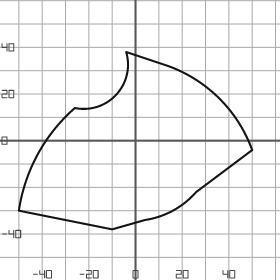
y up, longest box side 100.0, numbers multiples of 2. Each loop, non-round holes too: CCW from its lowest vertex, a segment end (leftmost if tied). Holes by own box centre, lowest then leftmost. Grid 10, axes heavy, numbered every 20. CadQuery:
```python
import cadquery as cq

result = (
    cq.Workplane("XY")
    .moveTo(-10.0, -38.0)
    .lineTo(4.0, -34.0)
    .threePointArc((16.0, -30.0), (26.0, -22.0))
    .lineTo(50.0, -4.0)
    .threePointArc((36.0, 18.0), (14.0, 32.0))
    .lineTo(-4.0, 38.0)
    .threePointArc((-8.0, 20.0), (-26.0, 14.0))
    .threePointArc((-42.0, -6.0), (-50.0, -30.0))
    .close()
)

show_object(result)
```